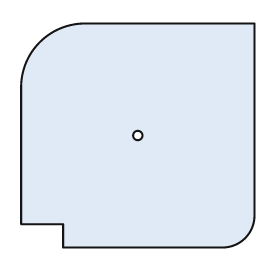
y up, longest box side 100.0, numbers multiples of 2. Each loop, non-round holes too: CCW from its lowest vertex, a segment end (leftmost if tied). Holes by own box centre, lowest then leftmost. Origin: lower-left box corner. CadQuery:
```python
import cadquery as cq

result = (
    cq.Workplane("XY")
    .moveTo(18.0, 0.0)
    .lineTo(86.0, 0.0)
    .threePointArc((96.0, 4.0), (100.0, 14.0))
    .lineTo(100.0, 96.0)
    .lineTo(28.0, 96.0)
    .threePointArc((8.0, 88.0), (0.0, 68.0))
    .lineTo(0.0, 10.0)
    .lineTo(18.0, 10.0)
    .close()
    .moveTo(50.0, 48.0)
    .circle(2.0)
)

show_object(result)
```